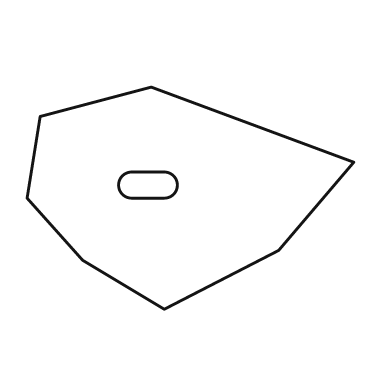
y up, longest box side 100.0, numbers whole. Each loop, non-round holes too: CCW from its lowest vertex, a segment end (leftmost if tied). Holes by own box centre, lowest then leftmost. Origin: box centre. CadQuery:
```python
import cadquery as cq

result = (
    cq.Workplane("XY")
    .moveTo(-8.0, -34.0)
    .lineTo(27.0, -16.0)
    .lineTo(50.0, 11.0)
    .lineTo(-12.0, 34.0)
    .lineTo(-46.0, 25.0)
    .lineTo(-50.0, 0.0)
    .lineTo(-33.0, -19.0)
    .close()
    .moveTo(-18.0, 0.0)
    .lineTo(-8.0, 0.0)
    .threePointArc((-4.0, 4.0), (-8.0, 8.0))
    .lineTo(-18.0, 8.0)
    .threePointArc((-22.0, 4.0), (-18.0, 0.0))
    .close()
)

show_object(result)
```